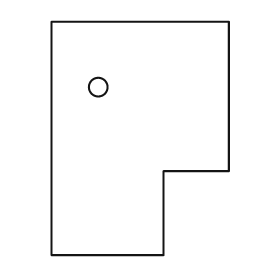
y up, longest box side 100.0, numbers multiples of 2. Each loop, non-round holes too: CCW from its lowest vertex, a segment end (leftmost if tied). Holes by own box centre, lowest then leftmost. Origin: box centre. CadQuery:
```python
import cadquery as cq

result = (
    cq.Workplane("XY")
    .moveTo(-38.0, -50.0)
    .lineTo(10.0, -50.0)
    .lineTo(10.0, -14.0)
    .lineTo(38.0, -14.0)
    .lineTo(38.0, 50.0)
    .lineTo(-38.0, 50.0)
    .close()
    .moveTo(-18.0, 22.0)
    .circle(4.0)
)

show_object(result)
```